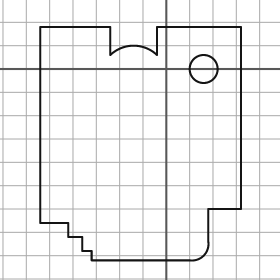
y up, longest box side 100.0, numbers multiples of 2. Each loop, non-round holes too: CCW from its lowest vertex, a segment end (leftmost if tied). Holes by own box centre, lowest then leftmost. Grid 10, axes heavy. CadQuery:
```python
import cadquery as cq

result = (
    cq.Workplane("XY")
    .moveTo(-32.0, -82.0)
    .lineTo(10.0, -82.0)
    .threePointArc((16.0, -80.0), (18.0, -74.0))
    .lineTo(18.0, -60.0)
    .lineTo(32.0, -60.0)
    .lineTo(32.0, 18.0)
    .lineTo(-4.0, 18.0)
    .lineTo(-4.0, 6.0)
    .threePointArc((-14.0, 10.0), (-24.0, 6.0))
    .lineTo(-24.0, 18.0)
    .lineTo(-54.0, 18.0)
    .lineTo(-54.0, -66.0)
    .lineTo(-42.0, -66.0)
    .lineTo(-42.0, -72.0)
    .lineTo(-36.0, -72.0)
    .lineTo(-36.0, -78.0)
    .lineTo(-32.0, -78.0)
    .close()
    .moveTo(16.0, 0.0)
    .circle(6.0)
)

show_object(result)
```